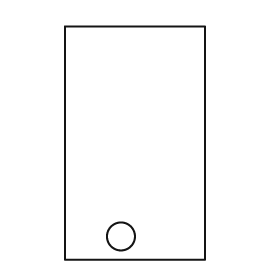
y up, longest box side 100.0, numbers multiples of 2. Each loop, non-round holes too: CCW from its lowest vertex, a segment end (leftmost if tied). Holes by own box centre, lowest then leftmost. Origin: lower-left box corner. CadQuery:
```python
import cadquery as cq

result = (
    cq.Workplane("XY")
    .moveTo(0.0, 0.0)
    .lineTo(60.0, 0.0)
    .lineTo(60.0, 100.0)
    .lineTo(0.0, 100.0)
    .close()
    .moveTo(24.0, 10.0)
    .circle(6.0)
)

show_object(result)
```